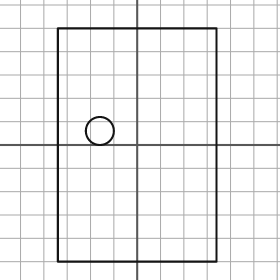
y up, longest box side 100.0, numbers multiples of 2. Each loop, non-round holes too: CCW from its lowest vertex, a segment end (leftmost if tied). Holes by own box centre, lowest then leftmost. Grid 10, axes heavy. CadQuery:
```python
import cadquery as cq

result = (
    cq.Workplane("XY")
    .moveTo(-34.0, -50.0)
    .lineTo(34.0, -50.0)
    .lineTo(34.0, 50.0)
    .lineTo(-34.0, 50.0)
    .close()
    .moveTo(-16.0, 6.0)
    .circle(6.0)
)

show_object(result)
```